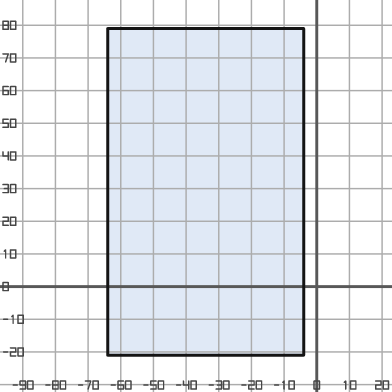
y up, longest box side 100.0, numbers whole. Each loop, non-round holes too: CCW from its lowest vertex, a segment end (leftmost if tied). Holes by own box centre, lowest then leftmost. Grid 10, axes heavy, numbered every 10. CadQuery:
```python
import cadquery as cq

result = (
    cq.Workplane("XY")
    .moveTo(-64.0, -21.0)
    .lineTo(-4.0, -21.0)
    .lineTo(-4.0, 79.0)
    .lineTo(-64.0, 79.0)
    .close()
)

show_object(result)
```